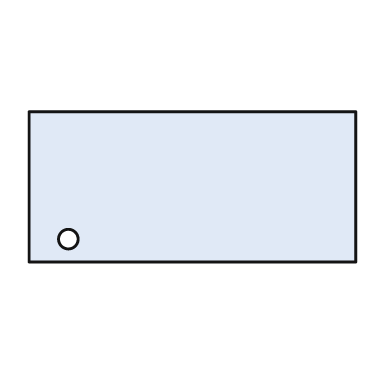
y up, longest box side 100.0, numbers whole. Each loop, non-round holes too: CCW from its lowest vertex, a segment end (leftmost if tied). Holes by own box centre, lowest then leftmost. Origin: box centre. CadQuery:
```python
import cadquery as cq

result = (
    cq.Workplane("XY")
    .moveTo(-50.0, -23.0)
    .lineTo(50.0, -23.0)
    .lineTo(50.0, 23.0)
    .lineTo(-50.0, 23.0)
    .close()
    .moveTo(-38.0, -16.0)
    .circle(3.0)
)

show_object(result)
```